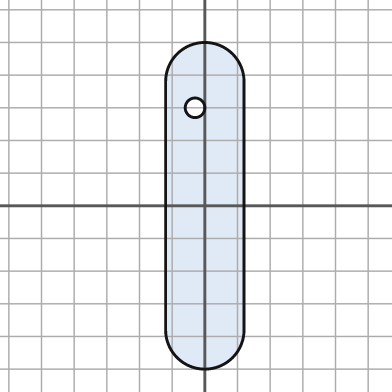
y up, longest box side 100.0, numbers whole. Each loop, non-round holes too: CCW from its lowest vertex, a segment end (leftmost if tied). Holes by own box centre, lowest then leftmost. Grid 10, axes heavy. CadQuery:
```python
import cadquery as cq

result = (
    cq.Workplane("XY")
    .moveTo(-12.0, -38.0)
    .threePointArc((0.0, -50.0), (12.0, -38.0))
    .lineTo(12.0, 38.0)
    .threePointArc((0.0, 50.0), (-12.0, 38.0))
    .close()
    .moveTo(-3.0, 30.0)
    .circle(3.0)
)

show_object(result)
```